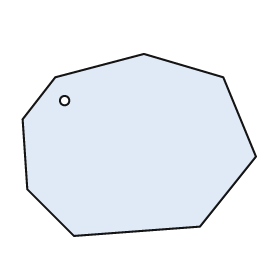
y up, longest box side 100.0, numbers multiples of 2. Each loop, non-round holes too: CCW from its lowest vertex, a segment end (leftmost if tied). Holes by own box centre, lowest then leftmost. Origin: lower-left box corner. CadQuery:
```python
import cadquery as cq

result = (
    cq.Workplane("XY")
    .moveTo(22.0, 0.0)
    .lineTo(76.0, 4.0)
    .lineTo(100.0, 34.0)
    .lineTo(86.0, 68.0)
    .lineTo(52.0, 78.0)
    .lineTo(14.0, 68.0)
    .lineTo(0.0, 50.0)
    .lineTo(2.0, 20.0)
    .close()
    .moveTo(18.0, 58.0)
    .circle(2.0)
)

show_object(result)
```